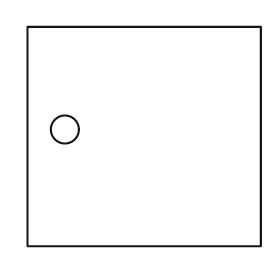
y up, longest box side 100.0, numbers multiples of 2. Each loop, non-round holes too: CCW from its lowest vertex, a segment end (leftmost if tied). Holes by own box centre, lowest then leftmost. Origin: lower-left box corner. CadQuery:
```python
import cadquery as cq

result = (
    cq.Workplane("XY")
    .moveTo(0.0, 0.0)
    .lineTo(100.0, 0.0)
    .lineTo(100.0, 94.0)
    .lineTo(0.0, 94.0)
    .close()
    .moveTo(16.0, 50.0)
    .circle(6.0)
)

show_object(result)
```